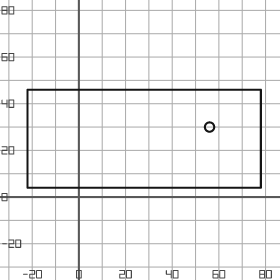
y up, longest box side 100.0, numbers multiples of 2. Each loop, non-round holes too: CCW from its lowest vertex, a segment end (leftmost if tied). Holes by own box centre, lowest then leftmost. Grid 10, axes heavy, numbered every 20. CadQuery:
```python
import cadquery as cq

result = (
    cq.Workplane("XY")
    .moveTo(-22.0, 4.0)
    .lineTo(78.0, 4.0)
    .lineTo(78.0, 46.0)
    .lineTo(-22.0, 46.0)
    .close()
    .moveTo(56.0, 30.0)
    .circle(2.0)
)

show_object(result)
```